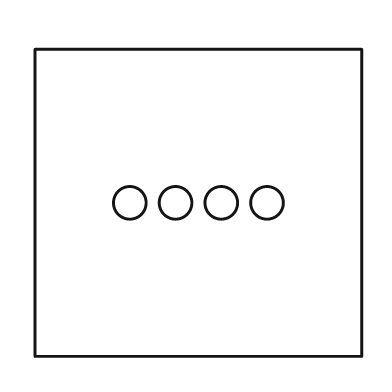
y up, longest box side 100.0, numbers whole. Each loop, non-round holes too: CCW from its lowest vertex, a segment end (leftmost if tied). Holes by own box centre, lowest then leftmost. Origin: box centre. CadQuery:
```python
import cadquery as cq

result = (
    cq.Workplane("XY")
    .moveTo(-50.0, -47.0)
    .lineTo(50.0, -47.0)
    .lineTo(50.0, 47.0)
    .lineTo(-50.0, 47.0)
    .close()
    .moveTo(-21.0, 0.0)
    .circle(5.0)
    .moveTo(-7.0, 0.0)
    .circle(5.0)
    .moveTo(7.0, 0.0)
    .circle(5.0)
    .moveTo(21.0, 0.0)
    .circle(5.0)
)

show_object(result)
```